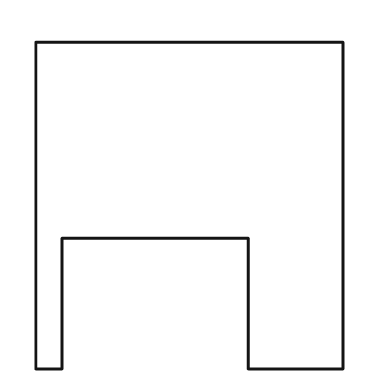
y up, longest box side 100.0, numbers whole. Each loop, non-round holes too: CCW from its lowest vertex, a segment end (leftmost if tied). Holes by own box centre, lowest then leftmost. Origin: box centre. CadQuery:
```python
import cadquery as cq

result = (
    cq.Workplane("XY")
    .moveTo(-47.0, -50.0)
    .lineTo(-39.0, -50.0)
    .lineTo(-39.0, -10.0)
    .lineTo(18.0, -10.0)
    .lineTo(18.0, -50.0)
    .lineTo(47.0, -50.0)
    .lineTo(47.0, 50.0)
    .lineTo(-47.0, 50.0)
    .close()
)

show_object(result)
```